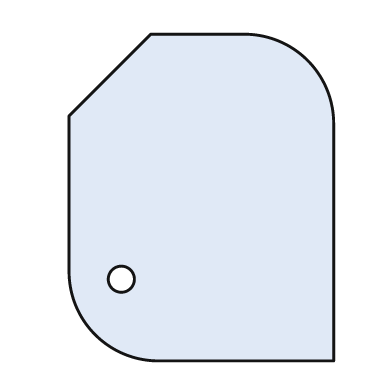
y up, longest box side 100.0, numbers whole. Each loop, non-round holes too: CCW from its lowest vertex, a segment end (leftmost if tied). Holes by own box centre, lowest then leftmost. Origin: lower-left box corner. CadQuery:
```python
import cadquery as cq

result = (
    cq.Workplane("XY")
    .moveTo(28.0, 0.0)
    .lineTo(81.0, 0.0)
    .lineTo(81.0, 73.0)
    .threePointArc((73.0, 92.0), (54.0, 100.0))
    .lineTo(25.0, 100.0)
    .lineTo(0.0, 75.0)
    .lineTo(0.0, 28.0)
    .threePointArc((8.0, 8.0), (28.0, 0.0))
    .close()
    .moveTo(16.0, 25.0)
    .circle(4.0)
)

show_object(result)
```